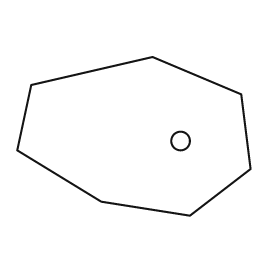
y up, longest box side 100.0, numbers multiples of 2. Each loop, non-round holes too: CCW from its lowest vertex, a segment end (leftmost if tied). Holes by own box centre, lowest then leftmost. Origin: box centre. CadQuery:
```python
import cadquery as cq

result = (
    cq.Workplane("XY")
    .moveTo(24.0, -34.0)
    .lineTo(50.0, -14.0)
    .lineTo(46.0, 18.0)
    .lineTo(8.0, 34.0)
    .lineTo(-44.0, 22.0)
    .lineTo(-50.0, -6.0)
    .lineTo(-14.0, -28.0)
    .close()
    .moveTo(20.0, -2.0)
    .circle(4.0)
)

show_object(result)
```